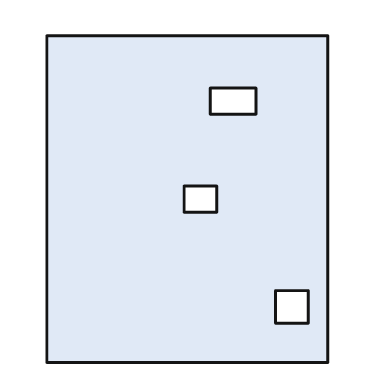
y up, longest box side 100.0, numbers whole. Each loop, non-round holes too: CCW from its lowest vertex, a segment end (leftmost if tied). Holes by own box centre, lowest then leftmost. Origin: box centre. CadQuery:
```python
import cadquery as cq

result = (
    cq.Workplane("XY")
    .moveTo(-43.0, -50.0)
    .lineTo(43.0, -50.0)
    .lineTo(43.0, 50.0)
    .lineTo(-43.0, 50.0)
    .close()
    .moveTo(27.0, -38.0)
    .lineTo(37.0, -38.0)
    .lineTo(37.0, -28.0)
    .lineTo(27.0, -28.0)
    .close()
    .moveTo(-1.0, -4.0)
    .lineTo(9.0, -4.0)
    .lineTo(9.0, 4.0)
    .lineTo(-1.0, 4.0)
    .close()
    .moveTo(7.0, 26.0)
    .lineTo(21.0, 26.0)
    .lineTo(21.0, 34.0)
    .lineTo(7.0, 34.0)
    .close()
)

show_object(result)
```